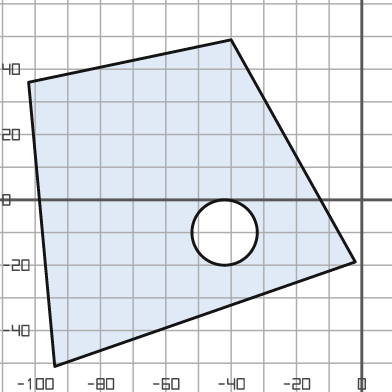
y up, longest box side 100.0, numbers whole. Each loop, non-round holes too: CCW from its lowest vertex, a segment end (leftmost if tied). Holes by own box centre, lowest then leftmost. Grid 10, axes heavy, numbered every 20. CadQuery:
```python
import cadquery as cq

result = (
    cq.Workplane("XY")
    .moveTo(-94.0, -51.0)
    .lineTo(-2.0, -19.0)
    .lineTo(-40.0, 49.0)
    .lineTo(-102.0, 36.0)
    .close()
    .moveTo(-42.0, -10.0)
    .circle(10.0)
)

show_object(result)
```